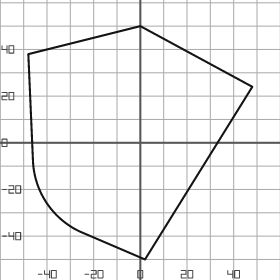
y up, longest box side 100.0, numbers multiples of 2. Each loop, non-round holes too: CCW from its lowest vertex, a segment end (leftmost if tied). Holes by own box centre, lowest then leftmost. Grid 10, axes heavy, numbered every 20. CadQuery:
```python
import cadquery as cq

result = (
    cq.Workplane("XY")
    .moveTo(2.0, -50.0)
    .lineTo(48.0, 24.0)
    .lineTo(0.0, 50.0)
    .lineTo(-48.0, 38.0)
    .lineTo(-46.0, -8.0)
    .threePointArc((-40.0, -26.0), (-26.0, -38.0))
    .close()
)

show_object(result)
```